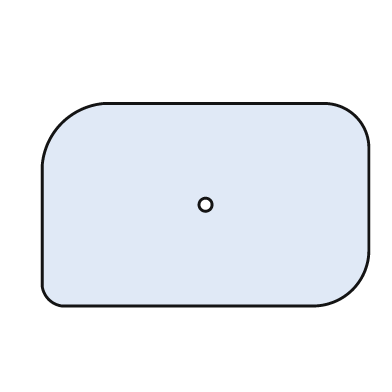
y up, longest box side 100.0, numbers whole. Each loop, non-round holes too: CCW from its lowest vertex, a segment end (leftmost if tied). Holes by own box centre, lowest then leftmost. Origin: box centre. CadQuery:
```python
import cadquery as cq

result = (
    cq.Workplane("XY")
    .moveTo(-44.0, -31.0)
    .lineTo(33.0, -31.0)
    .threePointArc((45.0, -26.0), (50.0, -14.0))
    .lineTo(50.0, 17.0)
    .threePointArc((46.0, 27.0), (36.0, 31.0))
    .lineTo(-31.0, 31.0)
    .threePointArc((-44.0, 25.0), (-50.0, 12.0))
    .lineTo(-50.0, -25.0)
    .threePointArc((-48.0, -29.0), (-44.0, -31.0))
    .close()
    .moveTo(0.0, 0.0)
    .circle(2.0)
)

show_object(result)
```